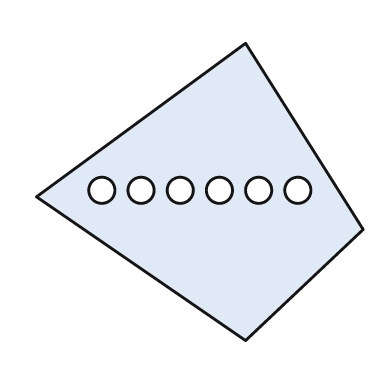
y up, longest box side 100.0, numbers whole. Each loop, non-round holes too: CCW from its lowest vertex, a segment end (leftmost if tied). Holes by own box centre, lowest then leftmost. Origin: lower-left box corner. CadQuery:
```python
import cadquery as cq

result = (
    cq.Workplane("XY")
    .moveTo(64.0, 0.0)
    .lineTo(100.0, 34.0)
    .lineTo(64.0, 91.0)
    .lineTo(0.0, 44.0)
    .close()
    .moveTo(20.0, 46.0)
    .circle(4.0)
    .moveTo(32.0, 46.0)
    .circle(4.0)
    .moveTo(44.0, 46.0)
    .circle(4.0)
    .moveTo(56.0, 46.0)
    .circle(4.0)
    .moveTo(68.0, 46.0)
    .circle(4.0)
    .moveTo(80.0, 46.0)
    .circle(4.0)
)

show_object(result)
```